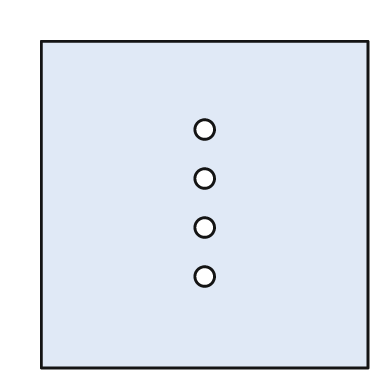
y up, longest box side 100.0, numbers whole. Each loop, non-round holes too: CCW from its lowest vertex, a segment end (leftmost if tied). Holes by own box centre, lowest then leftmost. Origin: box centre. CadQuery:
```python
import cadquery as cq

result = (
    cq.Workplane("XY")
    .moveTo(-50.0, -50.0)
    .lineTo(50.0, -50.0)
    .lineTo(50.0, 50.0)
    .lineTo(-50.0, 50.0)
    .close()
    .moveTo(0.0, -22.0)
    .circle(3.0)
    .moveTo(0.0, -7.0)
    .circle(3.0)
    .moveTo(0.0, 8.0)
    .circle(3.0)
    .moveTo(0.0, 23.0)
    .circle(3.0)
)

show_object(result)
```